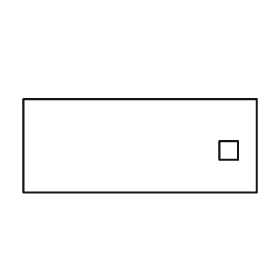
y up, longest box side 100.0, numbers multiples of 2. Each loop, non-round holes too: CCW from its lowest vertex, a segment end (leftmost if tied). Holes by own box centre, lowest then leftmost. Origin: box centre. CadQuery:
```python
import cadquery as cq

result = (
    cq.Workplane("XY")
    .moveTo(-50.0, -20.0)
    .lineTo(50.0, -20.0)
    .lineTo(50.0, 20.0)
    .lineTo(-50.0, 20.0)
    .close()
    .moveTo(34.0, -6.0)
    .lineTo(42.0, -6.0)
    .lineTo(42.0, 2.0)
    .lineTo(34.0, 2.0)
    .close()
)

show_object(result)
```